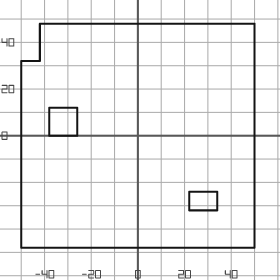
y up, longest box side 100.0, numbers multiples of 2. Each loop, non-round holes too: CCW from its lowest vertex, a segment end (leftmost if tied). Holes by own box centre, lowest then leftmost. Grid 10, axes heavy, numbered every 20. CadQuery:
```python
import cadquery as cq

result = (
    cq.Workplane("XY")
    .moveTo(-50.0, -48.0)
    .lineTo(50.0, -48.0)
    .lineTo(50.0, 48.0)
    .lineTo(-42.0, 48.0)
    .lineTo(-42.0, 32.0)
    .lineTo(-50.0, 32.0)
    .close()
    .moveTo(22.0, -32.0)
    .lineTo(34.0, -32.0)
    .lineTo(34.0, -24.0)
    .lineTo(22.0, -24.0)
    .close()
    .moveTo(-38.0, 0.0)
    .lineTo(-26.0, 0.0)
    .lineTo(-26.0, 12.0)
    .lineTo(-38.0, 12.0)
    .close()
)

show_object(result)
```